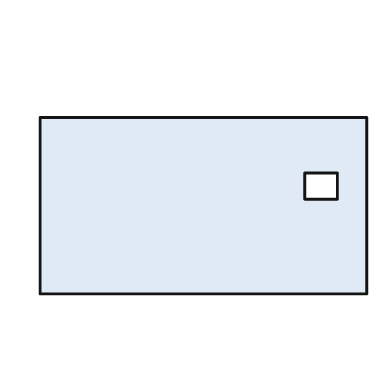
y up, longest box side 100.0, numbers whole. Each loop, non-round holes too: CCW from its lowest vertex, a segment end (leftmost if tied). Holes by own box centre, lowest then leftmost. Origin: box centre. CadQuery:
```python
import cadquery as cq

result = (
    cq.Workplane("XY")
    .moveTo(-50.0, -27.0)
    .lineTo(50.0, -27.0)
    .lineTo(50.0, 27.0)
    .lineTo(-50.0, 27.0)
    .close()
    .moveTo(31.0, 2.0)
    .lineTo(41.0, 2.0)
    .lineTo(41.0, 10.0)
    .lineTo(31.0, 10.0)
    .close()
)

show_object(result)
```